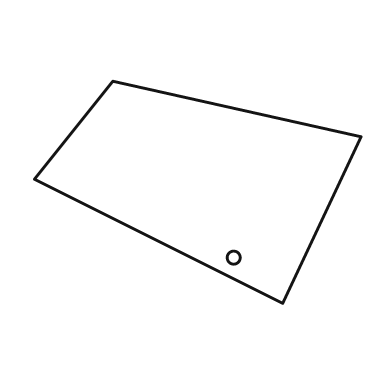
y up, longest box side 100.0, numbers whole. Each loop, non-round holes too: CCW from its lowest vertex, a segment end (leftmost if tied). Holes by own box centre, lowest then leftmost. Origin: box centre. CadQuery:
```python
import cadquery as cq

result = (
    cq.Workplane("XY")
    .moveTo(26.0, -34.0)
    .lineTo(50.0, 17.0)
    .lineTo(-26.0, 34.0)
    .lineTo(-50.0, 4.0)
    .close()
    .moveTo(11.0, -20.0)
    .circle(2.0)
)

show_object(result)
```